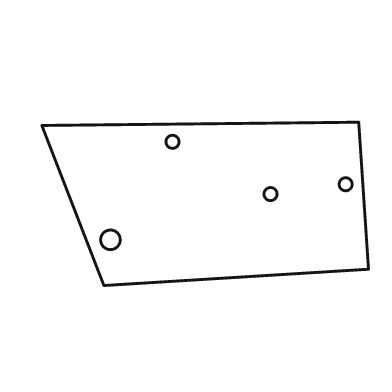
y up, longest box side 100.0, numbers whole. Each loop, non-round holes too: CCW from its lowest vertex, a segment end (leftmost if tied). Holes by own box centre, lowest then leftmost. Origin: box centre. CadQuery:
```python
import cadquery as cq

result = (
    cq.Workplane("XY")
    .moveTo(-31.0, -25.0)
    .lineTo(50.0, -20.0)
    .lineTo(47.0, 25.0)
    .lineTo(-50.0, 24.0)
    .close()
    .moveTo(-29.0, -11.0)
    .circle(3.0)
    .moveTo(20.0, 3.0)
    .circle(2.0)
    .moveTo(43.0, 6.0)
    .circle(2.0)
    .moveTo(-10.0, 19.0)
    .circle(2.0)
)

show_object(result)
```